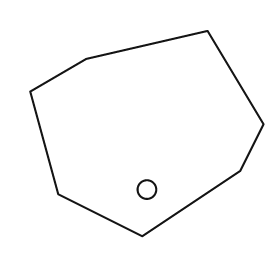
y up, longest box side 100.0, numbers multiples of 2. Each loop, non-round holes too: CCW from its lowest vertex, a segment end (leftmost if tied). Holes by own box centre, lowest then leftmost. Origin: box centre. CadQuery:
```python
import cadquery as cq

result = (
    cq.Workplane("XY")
    .moveTo(-2.0, -44.0)
    .lineTo(40.0, -16.0)
    .lineTo(50.0, 4.0)
    .lineTo(26.0, 44.0)
    .lineTo(-26.0, 32.0)
    .lineTo(-50.0, 18.0)
    .lineTo(-38.0, -26.0)
    .close()
    .moveTo(0.0, -24.0)
    .circle(4.0)
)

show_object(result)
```